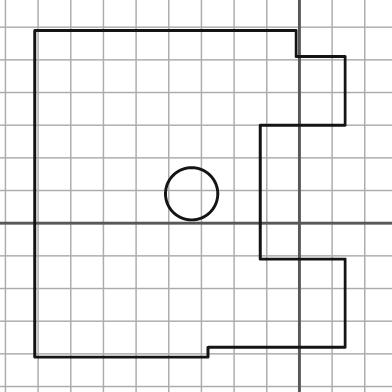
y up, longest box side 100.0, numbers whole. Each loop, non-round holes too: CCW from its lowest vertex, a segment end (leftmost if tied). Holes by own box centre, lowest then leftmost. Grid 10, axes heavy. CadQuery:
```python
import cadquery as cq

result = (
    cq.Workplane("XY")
    .moveTo(-81.0, -41.0)
    .lineTo(-28.0, -41.0)
    .lineTo(-28.0, -38.0)
    .lineTo(14.0, -38.0)
    .lineTo(14.0, -11.0)
    .lineTo(-12.0, -11.0)
    .lineTo(-12.0, 30.0)
    .lineTo(14.0, 30.0)
    .lineTo(14.0, 51.0)
    .lineTo(-1.0, 51.0)
    .lineTo(-1.0, 59.0)
    .lineTo(-81.0, 59.0)
    .close()
    .moveTo(-33.0, 9.0)
    .circle(8.0)
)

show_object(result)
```